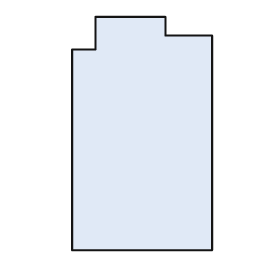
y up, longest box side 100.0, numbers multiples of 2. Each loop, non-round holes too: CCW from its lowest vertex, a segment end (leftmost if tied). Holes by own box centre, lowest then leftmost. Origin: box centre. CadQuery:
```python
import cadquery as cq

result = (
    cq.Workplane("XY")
    .moveTo(-30.0, -50.0)
    .lineTo(30.0, -50.0)
    .lineTo(30.0, 42.0)
    .lineTo(10.0, 42.0)
    .lineTo(10.0, 50.0)
    .lineTo(-20.0, 50.0)
    .lineTo(-20.0, 36.0)
    .lineTo(-30.0, 36.0)
    .close()
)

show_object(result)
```